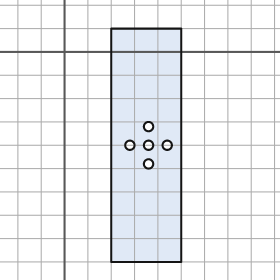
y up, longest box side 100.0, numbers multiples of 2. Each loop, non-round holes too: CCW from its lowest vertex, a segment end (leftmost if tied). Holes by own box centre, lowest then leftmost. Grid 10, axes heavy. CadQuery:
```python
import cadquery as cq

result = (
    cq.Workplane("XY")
    .moveTo(20.0, -90.0)
    .lineTo(50.0, -90.0)
    .lineTo(50.0, 10.0)
    .lineTo(20.0, 10.0)
    .close()
    .moveTo(36.0, -48.0)
    .circle(2.0)
    .moveTo(28.0, -40.0)
    .circle(2.0)
    .moveTo(36.0, -40.0)
    .circle(2.0)
    .moveTo(44.0, -40.0)
    .circle(2.0)
    .moveTo(36.0, -32.0)
    .circle(2.0)
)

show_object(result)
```